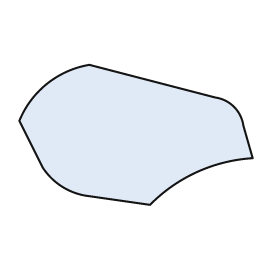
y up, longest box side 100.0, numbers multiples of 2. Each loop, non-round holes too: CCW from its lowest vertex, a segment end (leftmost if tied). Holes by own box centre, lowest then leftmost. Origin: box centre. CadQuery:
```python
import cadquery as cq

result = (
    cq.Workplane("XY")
    .moveTo(6.0, -30.0)
    .threePointArc((26.0, -16.0), (50.0, -10.0))
    .lineTo(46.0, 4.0)
    .threePointArc((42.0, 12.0), (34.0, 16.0))
    .lineTo(-20.0, 30.0)
    .threePointArc((-38.0, 22.0), (-50.0, 6.0))
    .lineTo(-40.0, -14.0)
    .threePointArc((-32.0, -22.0), (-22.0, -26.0))
    .close()
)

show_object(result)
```